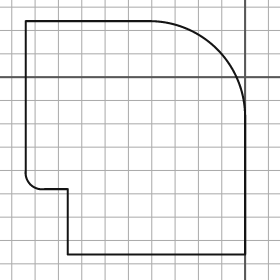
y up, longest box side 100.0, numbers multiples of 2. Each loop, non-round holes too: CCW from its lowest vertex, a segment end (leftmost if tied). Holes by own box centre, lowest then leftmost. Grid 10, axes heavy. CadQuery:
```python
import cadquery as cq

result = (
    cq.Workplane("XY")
    .moveTo(-76.0, -76.0)
    .lineTo(0.0, -76.0)
    .lineTo(0.0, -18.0)
    .threePointArc((-12.0, 12.0), (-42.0, 24.0))
    .lineTo(-94.0, 24.0)
    .lineTo(-94.0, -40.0)
    .threePointArc((-92.0, -46.0), (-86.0, -48.0))
    .lineTo(-76.0, -48.0)
    .close()
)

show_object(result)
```